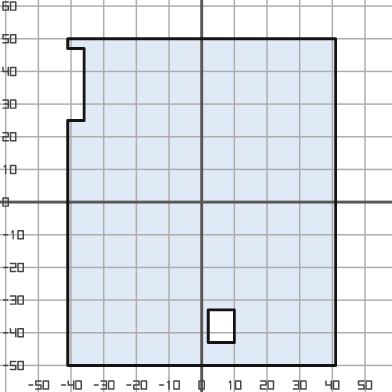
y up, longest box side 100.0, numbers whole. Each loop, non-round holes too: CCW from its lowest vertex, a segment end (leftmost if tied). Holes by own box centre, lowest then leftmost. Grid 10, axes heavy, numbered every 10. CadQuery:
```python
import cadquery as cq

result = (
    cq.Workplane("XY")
    .moveTo(-41.0, -50.0)
    .lineTo(41.0, -50.0)
    .lineTo(41.0, 50.0)
    .lineTo(-41.0, 50.0)
    .lineTo(-41.0, 47.0)
    .lineTo(-36.0, 47.0)
    .lineTo(-36.0, 25.0)
    .lineTo(-41.0, 25.0)
    .close()
    .moveTo(2.0, -43.0)
    .lineTo(10.0, -43.0)
    .lineTo(10.0, -33.0)
    .lineTo(2.0, -33.0)
    .close()
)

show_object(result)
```